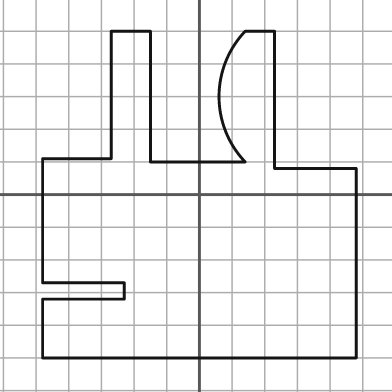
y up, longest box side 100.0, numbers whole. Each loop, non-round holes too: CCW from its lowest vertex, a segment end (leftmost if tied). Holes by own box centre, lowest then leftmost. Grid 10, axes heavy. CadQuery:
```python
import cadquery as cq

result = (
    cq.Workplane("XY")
    .moveTo(-48.0, -50.0)
    .lineTo(48.0, -50.0)
    .lineTo(48.0, 8.0)
    .lineTo(23.0, 8.0)
    .lineTo(23.0, 50.0)
    .lineTo(14.0, 50.0)
    .threePointArc((6.0, 30.0), (14.0, 10.0))
    .lineTo(-15.0, 10.0)
    .lineTo(-15.0, 50.0)
    .lineTo(-27.0, 50.0)
    .lineTo(-27.0, 11.0)
    .lineTo(-48.0, 11.0)
    .lineTo(-48.0, -27.0)
    .lineTo(-23.0, -27.0)
    .lineTo(-23.0, -32.0)
    .lineTo(-48.0, -32.0)
    .close()
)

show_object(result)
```